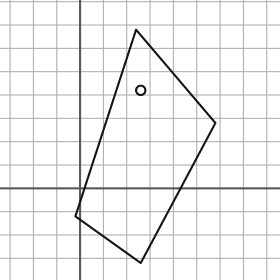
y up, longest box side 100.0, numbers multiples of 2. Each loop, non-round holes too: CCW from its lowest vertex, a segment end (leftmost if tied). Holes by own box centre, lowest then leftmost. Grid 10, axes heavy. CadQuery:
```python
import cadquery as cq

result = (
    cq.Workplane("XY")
    .moveTo(26.0, -32.0)
    .lineTo(58.0, 28.0)
    .lineTo(24.0, 68.0)
    .lineTo(-2.0, -12.0)
    .close()
    .moveTo(26.0, 42.0)
    .circle(2.0)
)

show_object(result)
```